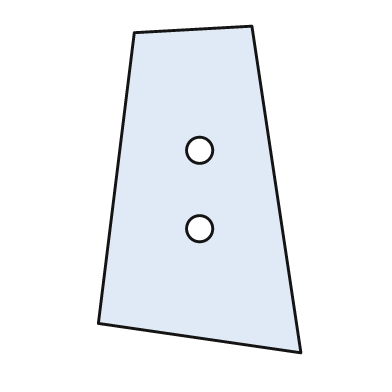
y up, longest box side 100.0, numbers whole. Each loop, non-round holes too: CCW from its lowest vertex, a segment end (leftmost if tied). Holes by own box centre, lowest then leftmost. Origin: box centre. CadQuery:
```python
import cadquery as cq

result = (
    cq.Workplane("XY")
    .moveTo(31.0, -50.0)
    .lineTo(16.0, 50.0)
    .lineTo(-20.0, 48.0)
    .lineTo(-31.0, -41.0)
    .close()
    .moveTo(0.0, -12.0)
    .circle(4.0)
    .moveTo(0.0, 12.0)
    .circle(4.0)
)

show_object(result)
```